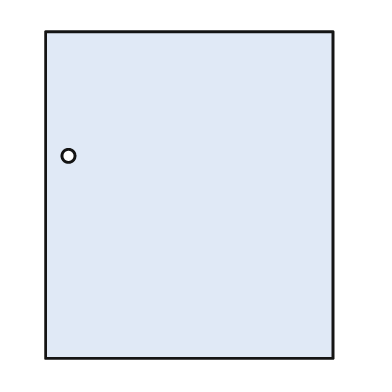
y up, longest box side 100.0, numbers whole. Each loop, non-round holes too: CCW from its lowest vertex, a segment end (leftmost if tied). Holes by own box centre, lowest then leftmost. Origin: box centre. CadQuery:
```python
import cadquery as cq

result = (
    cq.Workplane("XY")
    .moveTo(-44.0, -50.0)
    .lineTo(44.0, -50.0)
    .lineTo(44.0, 50.0)
    .lineTo(-44.0, 50.0)
    .close()
    .moveTo(-37.0, 12.0)
    .circle(2.0)
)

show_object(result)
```